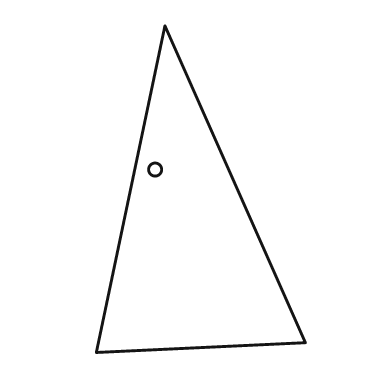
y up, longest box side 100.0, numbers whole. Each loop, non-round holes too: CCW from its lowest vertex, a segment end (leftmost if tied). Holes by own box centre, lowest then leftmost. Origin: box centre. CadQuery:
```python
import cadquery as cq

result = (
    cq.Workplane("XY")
    .moveTo(-32.0, -50.0)
    .lineTo(32.0, -47.0)
    .lineTo(-11.0, 50.0)
    .close()
    .moveTo(-14.0, 6.0)
    .circle(2.0)
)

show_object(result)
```